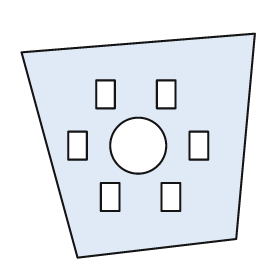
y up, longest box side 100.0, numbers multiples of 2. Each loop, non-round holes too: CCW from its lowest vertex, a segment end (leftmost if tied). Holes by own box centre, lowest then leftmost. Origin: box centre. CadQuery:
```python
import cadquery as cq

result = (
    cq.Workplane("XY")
    .moveTo(-26.0, -48.0)
    .lineTo(42.0, -40.0)
    .lineTo(50.0, 48.0)
    .lineTo(-50.0, 40.0)
    .close()
    .moveTo(-16.0, -28.0)
    .lineTo(-8.0, -28.0)
    .lineTo(-8.0, -16.0)
    .lineTo(-16.0, -16.0)
    .close()
    .moveTo(10.0, -28.0)
    .lineTo(18.0, -28.0)
    .lineTo(18.0, -16.0)
    .lineTo(10.0, -16.0)
    .close()
    .moveTo(-30.0, -6.0)
    .lineTo(-22.0, -6.0)
    .lineTo(-22.0, 6.0)
    .lineTo(-30.0, 6.0)
    .close()
    .moveTo(0.0, 0.0)
    .circle(12.0)
    .moveTo(22.0, -6.0)
    .lineTo(30.0, -6.0)
    .lineTo(30.0, 6.0)
    .lineTo(22.0, 6.0)
    .close()
    .moveTo(-18.0, 16.0)
    .lineTo(-10.0, 16.0)
    .lineTo(-10.0, 28.0)
    .lineTo(-18.0, 28.0)
    .close()
    .moveTo(8.0, 16.0)
    .lineTo(16.0, 16.0)
    .lineTo(16.0, 28.0)
    .lineTo(8.0, 28.0)
    .close()
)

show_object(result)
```